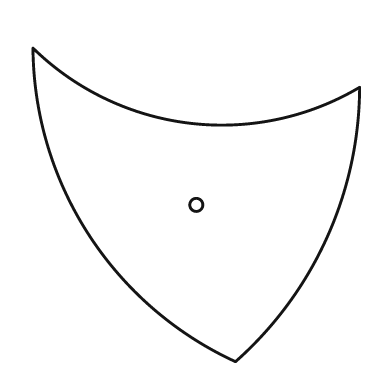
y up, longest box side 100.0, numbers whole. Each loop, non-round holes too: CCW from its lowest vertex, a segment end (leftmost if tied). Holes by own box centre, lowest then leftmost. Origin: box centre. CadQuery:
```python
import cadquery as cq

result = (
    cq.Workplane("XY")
    .moveTo(12.0, -48.0)
    .threePointArc((40.0, -10.0), (50.0, 36.0))
    .threePointArc((-2.0, 25.0), (-50.0, 48.0))
    .threePointArc((-33.0, -9.0), (12.0, -48.0))
    .close()
    .moveTo(0.0, 0.0)
    .circle(2.0)
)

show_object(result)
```